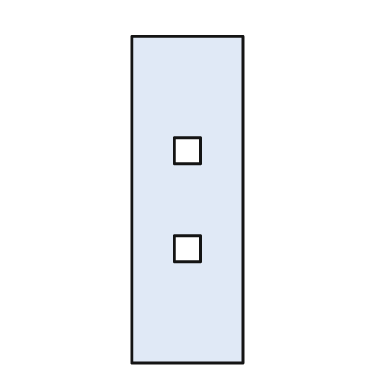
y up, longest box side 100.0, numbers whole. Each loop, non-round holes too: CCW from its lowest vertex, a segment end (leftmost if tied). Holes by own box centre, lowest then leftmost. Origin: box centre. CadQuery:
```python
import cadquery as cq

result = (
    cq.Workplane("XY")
    .moveTo(-17.0, -50.0)
    .lineTo(17.0, -50.0)
    .lineTo(17.0, 50.0)
    .lineTo(-17.0, 50.0)
    .close()
    .moveTo(-4.0, -19.0)
    .lineTo(4.0, -19.0)
    .lineTo(4.0, -11.0)
    .lineTo(-4.0, -11.0)
    .close()
    .moveTo(-4.0, 11.0)
    .lineTo(4.0, 11.0)
    .lineTo(4.0, 19.0)
    .lineTo(-4.0, 19.0)
    .close()
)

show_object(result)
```